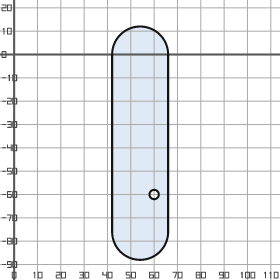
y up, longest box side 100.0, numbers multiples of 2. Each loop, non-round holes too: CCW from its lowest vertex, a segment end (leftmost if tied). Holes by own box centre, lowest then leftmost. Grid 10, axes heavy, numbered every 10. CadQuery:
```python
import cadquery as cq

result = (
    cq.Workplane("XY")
    .moveTo(42.0, -76.0)
    .threePointArc((54.0, -88.0), (66.0, -76.0))
    .lineTo(66.0, 0.0)
    .threePointArc((54.0, 12.0), (42.0, 0.0))
    .close()
    .moveTo(60.0, -60.0)
    .circle(2.0)
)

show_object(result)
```